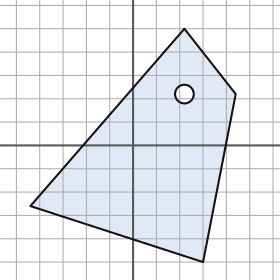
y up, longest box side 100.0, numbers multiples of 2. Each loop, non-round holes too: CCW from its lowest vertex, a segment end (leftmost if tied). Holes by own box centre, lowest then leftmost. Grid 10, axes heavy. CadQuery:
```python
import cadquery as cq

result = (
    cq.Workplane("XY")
    .moveTo(30.0, -50.0)
    .lineTo(44.0, 22.0)
    .lineTo(22.0, 50.0)
    .lineTo(-44.0, -26.0)
    .close()
    .moveTo(22.0, 22.0)
    .circle(4.0)
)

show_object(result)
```